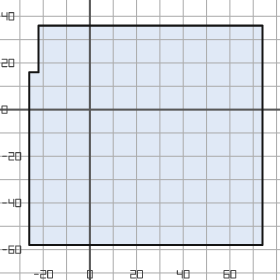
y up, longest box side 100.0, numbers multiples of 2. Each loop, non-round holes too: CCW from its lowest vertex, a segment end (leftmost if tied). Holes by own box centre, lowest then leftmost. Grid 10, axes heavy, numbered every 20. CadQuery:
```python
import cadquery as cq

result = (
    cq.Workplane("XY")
    .moveTo(-26.0, -58.0)
    .lineTo(74.0, -58.0)
    .lineTo(74.0, 36.0)
    .lineTo(-22.0, 36.0)
    .lineTo(-22.0, 16.0)
    .lineTo(-26.0, 16.0)
    .close()
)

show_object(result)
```